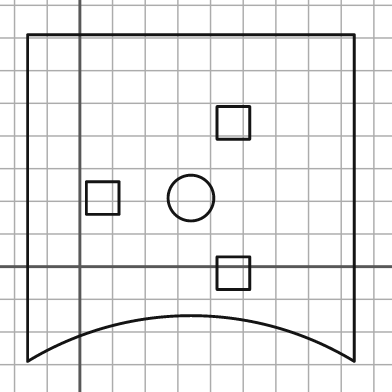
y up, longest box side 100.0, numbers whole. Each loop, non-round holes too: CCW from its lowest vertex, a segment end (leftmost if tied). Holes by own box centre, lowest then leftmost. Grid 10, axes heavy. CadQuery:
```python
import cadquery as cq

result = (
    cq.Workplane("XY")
    .moveTo(-16.0, -29.0)
    .threePointArc((34.0, -15.0), (84.0, -29.0))
    .lineTo(84.0, 71.0)
    .lineTo(-16.0, 71.0)
    .close()
    .moveTo(42.0, -7.0)
    .lineTo(52.0, -7.0)
    .lineTo(52.0, 3.0)
    .lineTo(42.0, 3.0)
    .close()
    .moveTo(2.0, 16.0)
    .lineTo(12.0, 16.0)
    .lineTo(12.0, 26.0)
    .lineTo(2.0, 26.0)
    .close()
    .moveTo(34.0, 21.0)
    .circle(7.0)
    .moveTo(42.0, 39.0)
    .lineTo(52.0, 39.0)
    .lineTo(52.0, 49.0)
    .lineTo(42.0, 49.0)
    .close()
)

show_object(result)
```